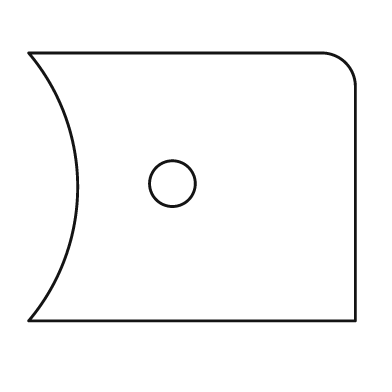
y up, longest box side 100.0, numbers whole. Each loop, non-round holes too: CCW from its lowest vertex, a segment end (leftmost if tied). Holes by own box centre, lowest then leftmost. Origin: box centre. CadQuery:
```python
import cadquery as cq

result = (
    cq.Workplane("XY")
    .moveTo(-50.0, -41.0)
    .lineTo(50.0, -41.0)
    .lineTo(50.0, 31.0)
    .threePointArc((47.0, 38.0), (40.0, 41.0))
    .lineTo(-50.0, 41.0)
    .threePointArc((-35.0, 0.0), (-50.0, -41.0))
    .close()
    .moveTo(-6.0, 1.0)
    .circle(7.0)
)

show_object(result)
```